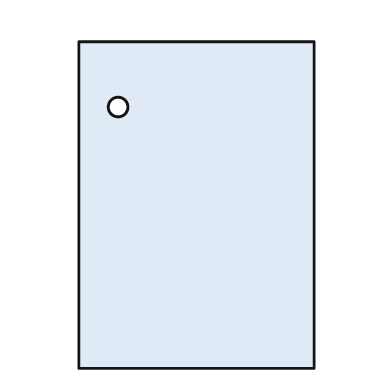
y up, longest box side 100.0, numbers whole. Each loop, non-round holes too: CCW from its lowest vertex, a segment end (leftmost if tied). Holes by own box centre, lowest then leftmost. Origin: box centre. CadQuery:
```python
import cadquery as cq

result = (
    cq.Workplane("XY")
    .moveTo(-36.0, -50.0)
    .lineTo(36.0, -50.0)
    .lineTo(36.0, 50.0)
    .lineTo(-36.0, 50.0)
    .close()
    .moveTo(-24.0, 30.0)
    .circle(3.0)
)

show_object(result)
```